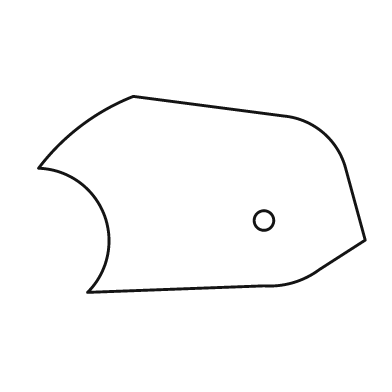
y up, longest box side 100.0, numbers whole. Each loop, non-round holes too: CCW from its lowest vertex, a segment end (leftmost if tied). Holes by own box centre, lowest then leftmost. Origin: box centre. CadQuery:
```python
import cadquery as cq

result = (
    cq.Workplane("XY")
    .moveTo(-35.0, -30.0)
    .lineTo(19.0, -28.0)
    .threePointArc((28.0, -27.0), (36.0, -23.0))
    .lineTo(50.0, -14.0)
    .lineTo(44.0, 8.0)
    .threePointArc((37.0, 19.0), (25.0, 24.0))
    .lineTo(-21.0, 30.0)
    .threePointArc((-37.0, 21.0), (-50.0, 8.0))
    .threePointArc((-30.0, -6.0), (-35.0, -30.0))
    .close()
    .moveTo(19.0, -8.0)
    .circle(3.0)
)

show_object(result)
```